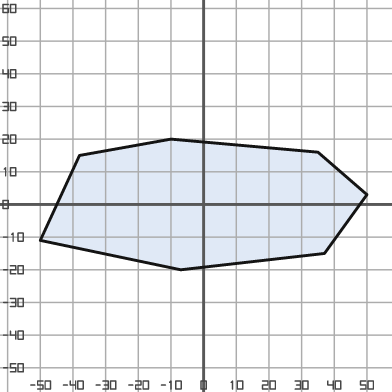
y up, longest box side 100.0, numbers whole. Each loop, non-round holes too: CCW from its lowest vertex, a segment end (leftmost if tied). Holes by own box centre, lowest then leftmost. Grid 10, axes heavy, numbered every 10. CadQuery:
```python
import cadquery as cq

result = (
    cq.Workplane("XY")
    .moveTo(-7.0, -20.0)
    .lineTo(37.0, -15.0)
    .lineTo(50.0, 3.0)
    .lineTo(35.0, 16.0)
    .lineTo(-10.0, 20.0)
    .lineTo(-38.0, 15.0)
    .lineTo(-50.0, -11.0)
    .close()
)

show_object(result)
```